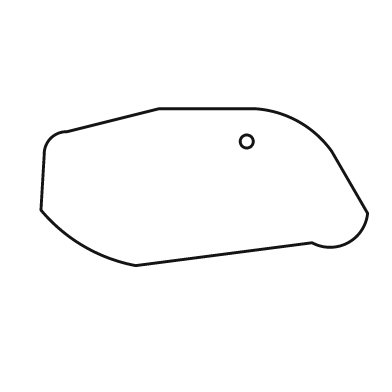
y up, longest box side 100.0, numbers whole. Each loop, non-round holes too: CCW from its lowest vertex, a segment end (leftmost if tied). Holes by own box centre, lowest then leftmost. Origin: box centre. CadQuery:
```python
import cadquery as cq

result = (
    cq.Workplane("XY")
    .moveTo(-21.0, -24.0)
    .lineTo(33.0, -17.0)
    .threePointArc((44.0, -17.0), (50.0, -8.0))
    .lineTo(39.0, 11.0)
    .threePointArc((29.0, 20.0), (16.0, 24.0))
    .lineTo(-14.0, 24.0)
    .lineTo(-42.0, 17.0)
    .threePointArc((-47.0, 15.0), (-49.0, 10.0))
    .lineTo(-50.0, -7.0)
    .threePointArc((-37.0, -18.0), (-21.0, -24.0))
    .close()
    .moveTo(13.0, 14.0)
    .circle(2.0)
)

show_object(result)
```